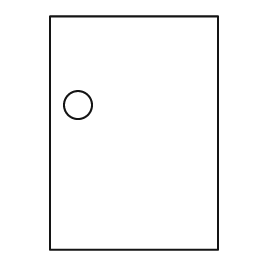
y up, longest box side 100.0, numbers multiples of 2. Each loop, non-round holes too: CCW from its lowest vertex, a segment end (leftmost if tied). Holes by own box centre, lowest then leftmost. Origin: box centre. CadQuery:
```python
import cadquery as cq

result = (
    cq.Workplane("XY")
    .moveTo(-36.0, -50.0)
    .lineTo(36.0, -50.0)
    .lineTo(36.0, 50.0)
    .lineTo(-36.0, 50.0)
    .close()
    .moveTo(-24.0, 12.0)
    .circle(6.0)
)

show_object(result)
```